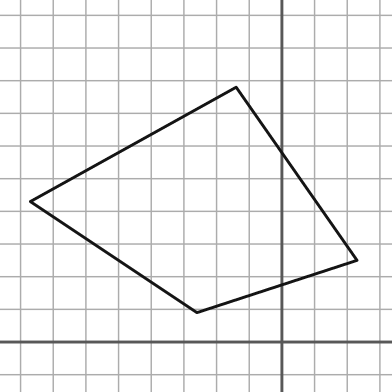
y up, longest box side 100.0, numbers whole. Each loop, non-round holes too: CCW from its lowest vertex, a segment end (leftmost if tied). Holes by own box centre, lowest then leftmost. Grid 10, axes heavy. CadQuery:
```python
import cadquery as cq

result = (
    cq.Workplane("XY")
    .moveTo(-26.0, 9.0)
    .lineTo(23.0, 25.0)
    .lineTo(-14.0, 78.0)
    .lineTo(-77.0, 43.0)
    .close()
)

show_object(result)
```